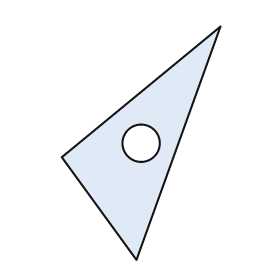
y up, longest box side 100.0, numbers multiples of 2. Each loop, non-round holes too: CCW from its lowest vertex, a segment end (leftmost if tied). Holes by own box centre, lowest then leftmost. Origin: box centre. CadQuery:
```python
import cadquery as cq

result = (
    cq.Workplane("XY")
    .moveTo(-2.0, -50.0)
    .lineTo(34.0, 50.0)
    .lineTo(-34.0, -6.0)
    .close()
    .moveTo(0.0, 0.0)
    .circle(8.0)
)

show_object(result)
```